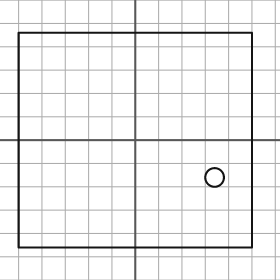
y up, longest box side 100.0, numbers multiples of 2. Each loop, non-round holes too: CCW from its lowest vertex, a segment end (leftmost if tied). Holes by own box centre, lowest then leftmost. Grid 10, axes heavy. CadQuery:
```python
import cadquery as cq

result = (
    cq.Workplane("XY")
    .moveTo(-50.0, -46.0)
    .lineTo(50.0, -46.0)
    .lineTo(50.0, 46.0)
    .lineTo(-50.0, 46.0)
    .close()
    .moveTo(34.0, -16.0)
    .circle(4.0)
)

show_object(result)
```